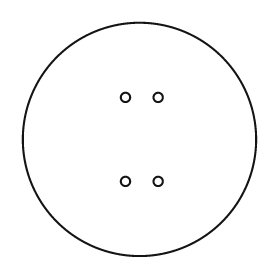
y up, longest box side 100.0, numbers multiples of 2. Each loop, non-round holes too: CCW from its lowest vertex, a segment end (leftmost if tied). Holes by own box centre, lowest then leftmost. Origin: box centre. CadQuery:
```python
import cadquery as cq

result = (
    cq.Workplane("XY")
    .moveTo(0.0, 0.0)
    .circle(50.0)
    .moveTo(-6.0, -18.0)
    .circle(2.0)
    .moveTo(8.0, -18.0)
    .circle(2.0)
    .moveTo(-6.0, 18.0)
    .circle(2.0)
    .moveTo(8.0, 18.0)
    .circle(2.0)
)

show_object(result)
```